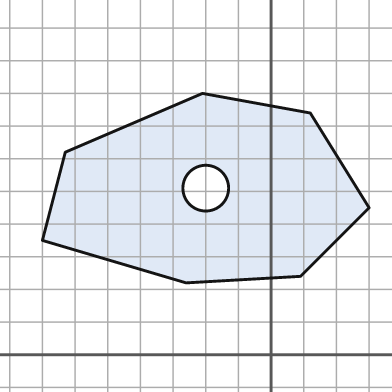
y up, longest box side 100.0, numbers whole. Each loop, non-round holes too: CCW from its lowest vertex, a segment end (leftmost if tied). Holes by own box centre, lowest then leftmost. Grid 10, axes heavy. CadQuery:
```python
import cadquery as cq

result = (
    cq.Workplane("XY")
    .moveTo(-26.0, 22.0)
    .lineTo(9.0, 24.0)
    .lineTo(30.0, 45.0)
    .lineTo(12.0, 74.0)
    .lineTo(-21.0, 80.0)
    .lineTo(-63.0, 62.0)
    .lineTo(-70.0, 35.0)
    .close()
    .moveTo(-20.0, 51.0)
    .circle(7.0)
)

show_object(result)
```